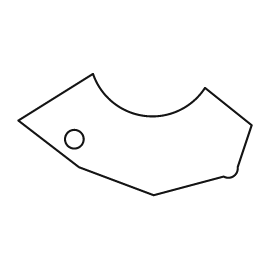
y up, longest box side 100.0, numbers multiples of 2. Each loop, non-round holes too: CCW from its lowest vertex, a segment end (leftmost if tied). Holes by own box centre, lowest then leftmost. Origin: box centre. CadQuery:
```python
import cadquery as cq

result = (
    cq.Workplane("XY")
    .moveTo(8.0, -26.0)
    .lineTo(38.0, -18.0)
    .threePointArc((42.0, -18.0), (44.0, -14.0))
    .lineTo(50.0, 4.0)
    .lineTo(30.0, 20.0)
    .threePointArc((4.0, 8.0), (-18.0, 26.0))
    .lineTo(-50.0, 6.0)
    .lineTo(-24.0, -14.0)
    .close()
    .moveTo(-26.0, -2.0)
    .circle(4.0)
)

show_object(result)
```